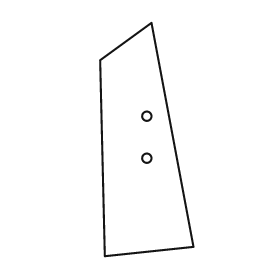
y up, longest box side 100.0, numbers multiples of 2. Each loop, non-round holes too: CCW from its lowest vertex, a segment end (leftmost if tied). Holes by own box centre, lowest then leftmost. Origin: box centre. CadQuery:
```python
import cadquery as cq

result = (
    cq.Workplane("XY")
    .moveTo(-18.0, -50.0)
    .lineTo(20.0, -46.0)
    .lineTo(2.0, 50.0)
    .lineTo(-20.0, 34.0)
    .close()
    .moveTo(0.0, -8.0)
    .circle(2.0)
    .moveTo(0.0, 10.0)
    .circle(2.0)
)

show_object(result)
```